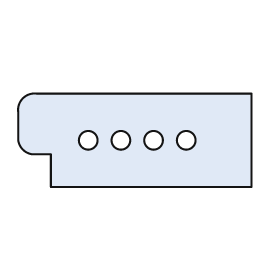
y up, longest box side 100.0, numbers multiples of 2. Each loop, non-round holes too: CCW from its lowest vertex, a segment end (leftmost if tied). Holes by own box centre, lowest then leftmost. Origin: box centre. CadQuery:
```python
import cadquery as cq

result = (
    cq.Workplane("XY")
    .moveTo(-36.0, -20.0)
    .lineTo(50.0, -20.0)
    .lineTo(50.0, 20.0)
    .lineTo(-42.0, 20.0)
    .threePointArc((-48.0, 18.0), (-50.0, 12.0))
    .lineTo(-50.0, 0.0)
    .threePointArc((-48.0, -4.0), (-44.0, -6.0))
    .lineTo(-36.0, -6.0)
    .close()
    .moveTo(-20.0, 0.0)
    .circle(4.0)
    .moveTo(-6.0, 0.0)
    .circle(4.0)
    .moveTo(8.0, 0.0)
    .circle(4.0)
    .moveTo(22.0, 0.0)
    .circle(4.0)
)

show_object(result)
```